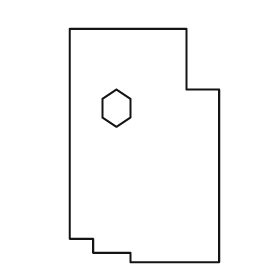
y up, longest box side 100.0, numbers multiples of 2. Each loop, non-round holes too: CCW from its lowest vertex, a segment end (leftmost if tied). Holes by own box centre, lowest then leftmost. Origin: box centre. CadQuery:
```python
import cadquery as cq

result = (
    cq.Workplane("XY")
    .moveTo(-6.0, -50.0)
    .lineTo(32.0, -50.0)
    .lineTo(32.0, 24.0)
    .lineTo(18.0, 24.0)
    .lineTo(18.0, 50.0)
    .lineTo(-32.0, 50.0)
    .lineTo(-32.0, -40.0)
    .lineTo(-22.0, -40.0)
    .lineTo(-22.0, -46.0)
    .lineTo(-6.0, -46.0)
    .close()
    .moveTo(-12.0, 8.0)
    .lineTo(-6.0, 12.0)
    .lineTo(-6.0, 20.0)
    .lineTo(-12.0, 24.0)
    .lineTo(-18.0, 20.0)
    .lineTo(-18.0, 12.0)
    .close()
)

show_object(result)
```